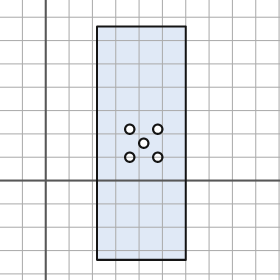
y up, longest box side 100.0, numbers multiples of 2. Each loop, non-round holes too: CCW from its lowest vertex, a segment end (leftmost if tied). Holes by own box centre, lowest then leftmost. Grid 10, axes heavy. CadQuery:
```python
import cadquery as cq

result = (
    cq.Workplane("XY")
    .moveTo(22.0, -34.0)
    .lineTo(60.0, -34.0)
    .lineTo(60.0, 66.0)
    .lineTo(22.0, 66.0)
    .close()
    .moveTo(36.0, 10.0)
    .circle(2.0)
    .moveTo(48.0, 10.0)
    .circle(2.0)
    .moveTo(42.0, 16.0)
    .circle(2.0)
    .moveTo(36.0, 22.0)
    .circle(2.0)
    .moveTo(48.0, 22.0)
    .circle(2.0)
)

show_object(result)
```